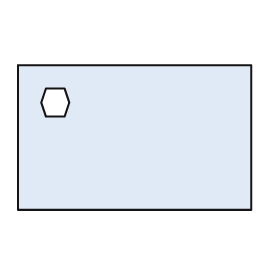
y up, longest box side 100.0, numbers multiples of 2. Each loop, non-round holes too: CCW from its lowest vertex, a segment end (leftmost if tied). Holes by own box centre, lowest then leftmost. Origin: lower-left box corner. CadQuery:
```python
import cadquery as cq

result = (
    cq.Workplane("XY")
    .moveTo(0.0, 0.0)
    .lineTo(100.0, 0.0)
    .lineTo(100.0, 62.0)
    .lineTo(0.0, 62.0)
    .close()
    .moveTo(12.0, 40.0)
    .lineTo(20.0, 40.0)
    .lineTo(22.0, 46.0)
    .lineTo(20.0, 52.0)
    .lineTo(12.0, 52.0)
    .lineTo(10.0, 46.0)
    .close()
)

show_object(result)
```